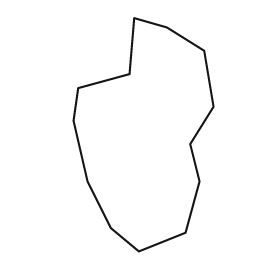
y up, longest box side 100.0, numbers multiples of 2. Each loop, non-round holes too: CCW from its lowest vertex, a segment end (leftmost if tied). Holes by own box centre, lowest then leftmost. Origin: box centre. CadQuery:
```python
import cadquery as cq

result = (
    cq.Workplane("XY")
    .moveTo(-2.0, -50.0)
    .lineTo(18.0, -42.0)
    .lineTo(24.0, -20.0)
    .lineTo(20.0, -4.0)
    .lineTo(30.0, 12.0)
    .lineTo(26.0, 36.0)
    .lineTo(10.0, 46.0)
    .lineTo(-4.0, 50.0)
    .lineTo(-6.0, 26.0)
    .lineTo(-28.0, 20.0)
    .lineTo(-30.0, 6.0)
    .lineTo(-24.0, -20.0)
    .lineTo(-14.0, -40.0)
    .close()
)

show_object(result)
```